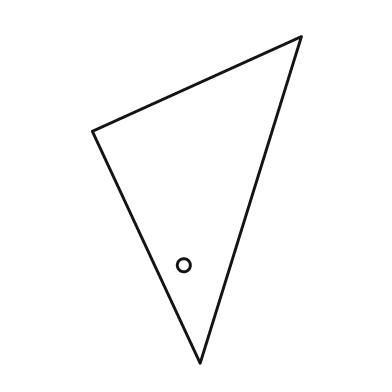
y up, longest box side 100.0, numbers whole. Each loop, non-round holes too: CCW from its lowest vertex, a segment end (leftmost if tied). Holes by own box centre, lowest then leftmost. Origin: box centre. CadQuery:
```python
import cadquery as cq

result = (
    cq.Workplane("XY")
    .moveTo(1.0, -50.0)
    .lineTo(32.0, 50.0)
    .lineTo(-32.0, 21.0)
    .close()
    .moveTo(-4.0, -20.0)
    .circle(2.0)
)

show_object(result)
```